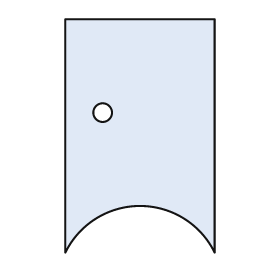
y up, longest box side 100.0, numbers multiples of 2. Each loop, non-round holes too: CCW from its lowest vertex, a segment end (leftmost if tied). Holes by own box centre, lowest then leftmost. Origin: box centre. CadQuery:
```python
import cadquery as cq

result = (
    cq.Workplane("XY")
    .moveTo(-32.0, -50.0)
    .threePointArc((0.0, -30.0), (32.0, -50.0))
    .lineTo(32.0, 50.0)
    .lineTo(-32.0, 50.0)
    .close()
    .moveTo(-16.0, 10.0)
    .circle(4.0)
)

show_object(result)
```